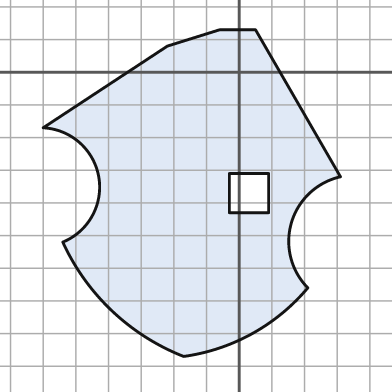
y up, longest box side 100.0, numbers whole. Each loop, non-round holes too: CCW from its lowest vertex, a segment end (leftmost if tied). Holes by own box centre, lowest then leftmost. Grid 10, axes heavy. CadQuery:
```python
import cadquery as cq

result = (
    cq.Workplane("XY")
    .moveTo(-17.0, -87.0)
    .threePointArc((4.0, -80.0), (21.0, -66.0))
    .threePointArc((16.0, -46.0), (31.0, -32.0))
    .lineTo(5.0, 13.0)
    .lineTo(-6.0, 13.0)
    .lineTo(-22.0, 8.0)
    .lineTo(-60.0, -17.0)
    .threePointArc((-43.0, -32.0), (-54.0, -52.0))
    .threePointArc((-39.0, -73.0), (-17.0, -87.0))
    .close()
    .moveTo(-3.0, -43.0)
    .lineTo(9.0, -43.0)
    .lineTo(9.0, -31.0)
    .lineTo(-3.0, -31.0)
    .close()
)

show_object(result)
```